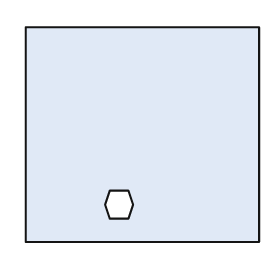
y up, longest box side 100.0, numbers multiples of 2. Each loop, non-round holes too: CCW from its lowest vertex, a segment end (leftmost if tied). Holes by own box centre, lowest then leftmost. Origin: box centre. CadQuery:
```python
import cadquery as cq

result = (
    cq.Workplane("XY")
    .moveTo(-50.0, -46.0)
    .lineTo(50.0, -46.0)
    .lineTo(50.0, 46.0)
    .lineTo(-50.0, 46.0)
    .close()
    .moveTo(-14.0, -36.0)
    .lineTo(-6.0, -36.0)
    .lineTo(-4.0, -30.0)
    .lineTo(-6.0, -24.0)
    .lineTo(-14.0, -24.0)
    .lineTo(-16.0, -30.0)
    .close()
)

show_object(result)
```